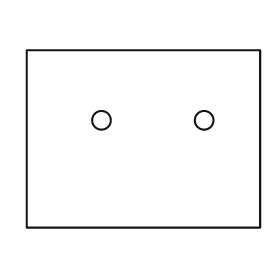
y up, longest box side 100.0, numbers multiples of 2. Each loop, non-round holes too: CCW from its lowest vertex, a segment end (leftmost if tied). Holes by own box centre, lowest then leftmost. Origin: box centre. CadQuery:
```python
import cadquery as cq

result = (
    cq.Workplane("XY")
    .moveTo(-50.0, -38.0)
    .lineTo(50.0, -38.0)
    .lineTo(50.0, 38.0)
    .lineTo(-50.0, 38.0)
    .close()
    .moveTo(-18.0, 8.0)
    .circle(4.0)
    .moveTo(26.0, 8.0)
    .circle(4.0)
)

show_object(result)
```